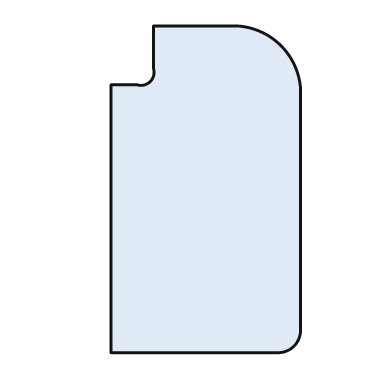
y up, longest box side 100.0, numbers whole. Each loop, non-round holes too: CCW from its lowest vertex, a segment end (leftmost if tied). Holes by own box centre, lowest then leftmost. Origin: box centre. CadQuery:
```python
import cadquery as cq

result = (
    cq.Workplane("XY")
    .moveTo(-29.0, -50.0)
    .lineTo(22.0, -50.0)
    .threePointArc((27.0, -48.0), (29.0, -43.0))
    .lineTo(29.0, 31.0)
    .threePointArc((23.0, 44.0), (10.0, 50.0))
    .lineTo(-16.0, 50.0)
    .lineTo(-16.0, 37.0)
    .threePointArc((-17.0, 33.0), (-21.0, 32.0))
    .lineTo(-29.0, 32.0)
    .close()
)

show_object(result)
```